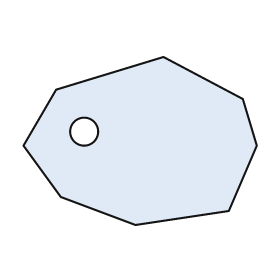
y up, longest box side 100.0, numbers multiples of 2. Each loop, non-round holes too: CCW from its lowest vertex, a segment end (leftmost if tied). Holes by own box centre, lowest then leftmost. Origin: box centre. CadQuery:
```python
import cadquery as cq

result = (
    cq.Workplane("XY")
    .moveTo(-2.0, -36.0)
    .lineTo(38.0, -30.0)
    .lineTo(50.0, -2.0)
    .lineTo(44.0, 18.0)
    .lineTo(10.0, 36.0)
    .lineTo(-36.0, 22.0)
    .lineTo(-50.0, -2.0)
    .lineTo(-34.0, -24.0)
    .close()
    .moveTo(-24.0, 4.0)
    .circle(6.0)
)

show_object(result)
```